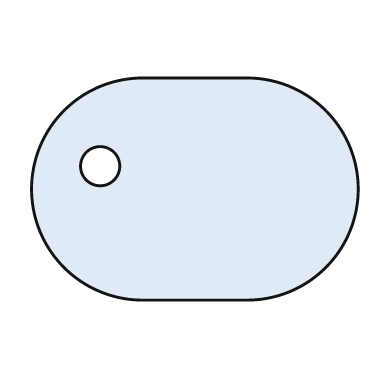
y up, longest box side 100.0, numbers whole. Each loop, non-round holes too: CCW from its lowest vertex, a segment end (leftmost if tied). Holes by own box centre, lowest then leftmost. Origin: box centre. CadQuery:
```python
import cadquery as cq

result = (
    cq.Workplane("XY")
    .moveTo(-16.0, -34.0)
    .lineTo(16.0, -34.0)
    .threePointArc((50.0, 0.0), (16.0, 34.0))
    .lineTo(-16.0, 34.0)
    .threePointArc((-50.0, 0.0), (-16.0, -34.0))
    .close()
    .moveTo(-29.0, 7.0)
    .circle(6.0)
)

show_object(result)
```